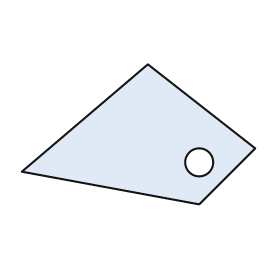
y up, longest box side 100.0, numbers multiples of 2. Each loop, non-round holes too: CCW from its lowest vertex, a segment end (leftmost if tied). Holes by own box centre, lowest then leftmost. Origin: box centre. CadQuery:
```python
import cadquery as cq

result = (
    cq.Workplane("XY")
    .moveTo(26.0, -30.0)
    .lineTo(50.0, -6.0)
    .lineTo(4.0, 30.0)
    .lineTo(-50.0, -16.0)
    .close()
    .moveTo(26.0, -12.0)
    .circle(6.0)
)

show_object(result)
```